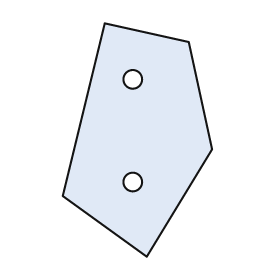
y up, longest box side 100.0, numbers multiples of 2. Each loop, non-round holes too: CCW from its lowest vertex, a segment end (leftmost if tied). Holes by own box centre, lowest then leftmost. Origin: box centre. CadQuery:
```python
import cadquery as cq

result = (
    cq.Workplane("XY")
    .moveTo(4.0, -50.0)
    .lineTo(32.0, -4.0)
    .lineTo(22.0, 42.0)
    .lineTo(-14.0, 50.0)
    .lineTo(-32.0, -24.0)
    .close()
    .moveTo(-2.0, -18.0)
    .circle(4.0)
    .moveTo(-2.0, 26.0)
    .circle(4.0)
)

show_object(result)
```